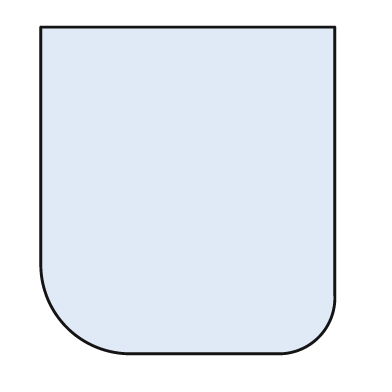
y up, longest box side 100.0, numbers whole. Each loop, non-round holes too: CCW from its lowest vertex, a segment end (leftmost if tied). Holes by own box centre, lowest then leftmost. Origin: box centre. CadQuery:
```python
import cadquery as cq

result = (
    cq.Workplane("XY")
    .moveTo(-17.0, -50.0)
    .lineTo(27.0, -50.0)
    .threePointArc((40.0, -45.0), (45.0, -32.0))
    .lineTo(45.0, 50.0)
    .lineTo(-45.0, 50.0)
    .lineTo(-45.0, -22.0)
    .threePointArc((-37.0, -42.0), (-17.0, -50.0))
    .close()
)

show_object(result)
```